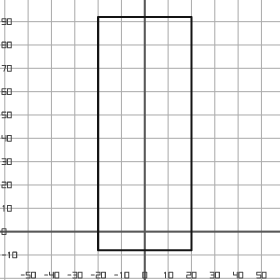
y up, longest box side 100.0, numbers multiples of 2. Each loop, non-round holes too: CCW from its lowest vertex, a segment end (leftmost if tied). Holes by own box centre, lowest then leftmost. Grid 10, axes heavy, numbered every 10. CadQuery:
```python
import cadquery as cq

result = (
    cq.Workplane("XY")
    .moveTo(-20.0, -8.0)
    .lineTo(20.0, -8.0)
    .lineTo(20.0, 92.0)
    .lineTo(-20.0, 92.0)
    .close()
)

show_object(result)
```